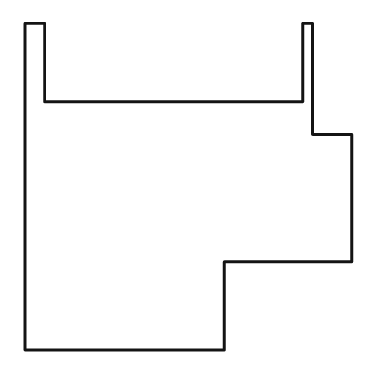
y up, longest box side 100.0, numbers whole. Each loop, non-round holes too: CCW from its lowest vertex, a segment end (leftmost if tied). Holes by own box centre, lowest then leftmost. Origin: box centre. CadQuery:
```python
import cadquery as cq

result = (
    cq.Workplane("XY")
    .moveTo(-50.0, -50.0)
    .lineTo(11.0, -50.0)
    .lineTo(11.0, -23.0)
    .lineTo(50.0, -23.0)
    .lineTo(50.0, 16.0)
    .lineTo(38.0, 16.0)
    .lineTo(38.0, 50.0)
    .lineTo(35.0, 50.0)
    .lineTo(35.0, 26.0)
    .lineTo(-44.0, 26.0)
    .lineTo(-44.0, 50.0)
    .lineTo(-50.0, 50.0)
    .close()
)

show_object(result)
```